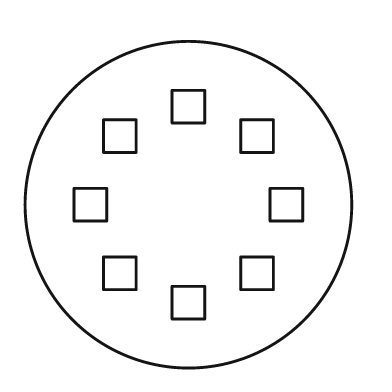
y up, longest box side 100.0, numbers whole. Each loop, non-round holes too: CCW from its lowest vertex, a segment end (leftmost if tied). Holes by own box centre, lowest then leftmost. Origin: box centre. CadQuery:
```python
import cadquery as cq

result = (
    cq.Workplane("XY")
    .moveTo(0.0, 0.0)
    .circle(50.0)
    .moveTo(-5.0, -35.0)
    .lineTo(5.0, -35.0)
    .lineTo(5.0, -25.0)
    .lineTo(-5.0, -25.0)
    .close()
    .moveTo(-26.0, -26.0)
    .lineTo(-16.0, -26.0)
    .lineTo(-16.0, -16.0)
    .lineTo(-26.0, -16.0)
    .close()
    .moveTo(16.0, -26.0)
    .lineTo(26.0, -26.0)
    .lineTo(26.0, -16.0)
    .lineTo(16.0, -16.0)
    .close()
    .moveTo(-35.0, -5.0)
    .lineTo(-25.0, -5.0)
    .lineTo(-25.0, 5.0)
    .lineTo(-35.0, 5.0)
    .close()
    .moveTo(25.0, -5.0)
    .lineTo(35.0, -5.0)
    .lineTo(35.0, 5.0)
    .lineTo(25.0, 5.0)
    .close()
    .moveTo(-26.0, 16.0)
    .lineTo(-16.0, 16.0)
    .lineTo(-16.0, 26.0)
    .lineTo(-26.0, 26.0)
    .close()
    .moveTo(16.0, 16.0)
    .lineTo(26.0, 16.0)
    .lineTo(26.0, 26.0)
    .lineTo(16.0, 26.0)
    .close()
    .moveTo(-5.0, 25.0)
    .lineTo(5.0, 25.0)
    .lineTo(5.0, 35.0)
    .lineTo(-5.0, 35.0)
    .close()
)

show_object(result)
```